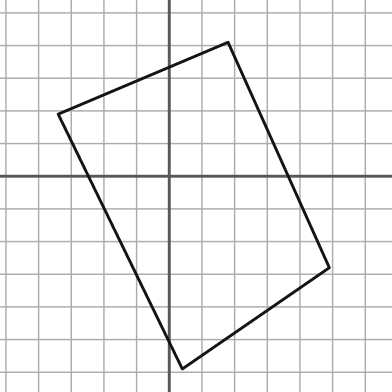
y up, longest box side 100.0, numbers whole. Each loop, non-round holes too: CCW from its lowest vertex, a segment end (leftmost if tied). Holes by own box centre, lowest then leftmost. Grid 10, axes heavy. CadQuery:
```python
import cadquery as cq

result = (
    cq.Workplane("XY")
    .moveTo(4.0, -59.0)
    .lineTo(49.0, -28.0)
    .lineTo(18.0, 41.0)
    .lineTo(-34.0, 19.0)
    .close()
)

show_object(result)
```